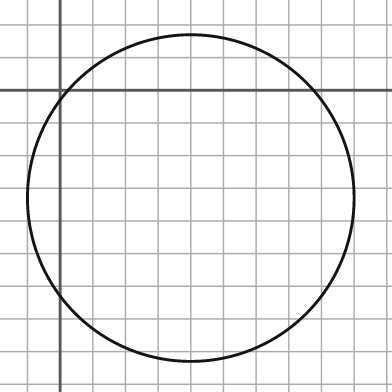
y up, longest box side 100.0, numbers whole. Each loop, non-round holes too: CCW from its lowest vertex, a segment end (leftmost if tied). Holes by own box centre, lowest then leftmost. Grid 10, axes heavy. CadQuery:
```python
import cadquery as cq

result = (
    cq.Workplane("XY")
    .moveTo(40.0, -33.0)
    .circle(50.0)
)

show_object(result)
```